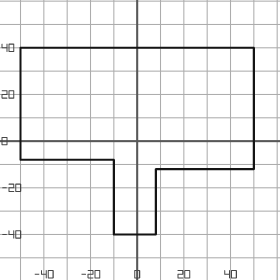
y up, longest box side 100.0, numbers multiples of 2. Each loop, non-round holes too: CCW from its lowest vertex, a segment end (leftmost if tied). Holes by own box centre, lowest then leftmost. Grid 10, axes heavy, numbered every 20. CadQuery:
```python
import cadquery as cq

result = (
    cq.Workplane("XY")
    .moveTo(-10.0, -40.0)
    .lineTo(8.0, -40.0)
    .lineTo(8.0, -12.0)
    .lineTo(50.0, -12.0)
    .lineTo(50.0, 40.0)
    .lineTo(-50.0, 40.0)
    .lineTo(-50.0, -8.0)
    .lineTo(-10.0, -8.0)
    .close()
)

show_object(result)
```